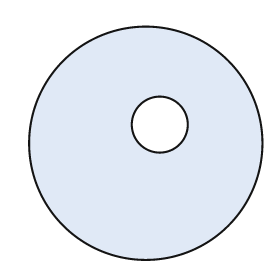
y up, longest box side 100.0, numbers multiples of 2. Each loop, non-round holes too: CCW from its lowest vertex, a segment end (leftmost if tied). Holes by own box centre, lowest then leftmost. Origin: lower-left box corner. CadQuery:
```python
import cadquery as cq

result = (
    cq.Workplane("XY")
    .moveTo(50.0, 50.0)
    .circle(50.0)
    .moveTo(56.0, 58.0)
    .circle(12.0)
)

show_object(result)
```